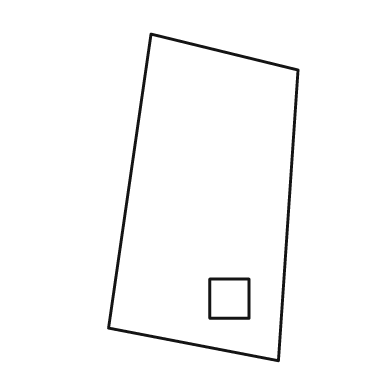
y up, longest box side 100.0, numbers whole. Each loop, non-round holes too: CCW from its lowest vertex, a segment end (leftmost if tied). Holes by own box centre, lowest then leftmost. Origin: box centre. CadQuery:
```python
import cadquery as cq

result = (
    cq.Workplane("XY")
    .moveTo(23.0, -50.0)
    .lineTo(29.0, 39.0)
    .lineTo(-16.0, 50.0)
    .lineTo(-29.0, -40.0)
    .close()
    .moveTo(2.0, -37.0)
    .lineTo(14.0, -37.0)
    .lineTo(14.0, -25.0)
    .lineTo(2.0, -25.0)
    .close()
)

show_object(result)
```